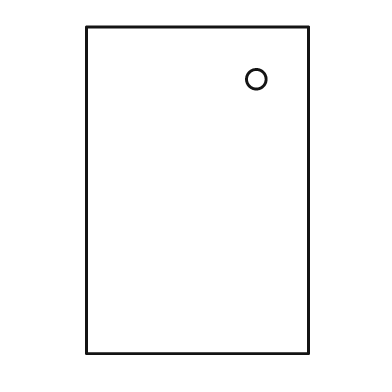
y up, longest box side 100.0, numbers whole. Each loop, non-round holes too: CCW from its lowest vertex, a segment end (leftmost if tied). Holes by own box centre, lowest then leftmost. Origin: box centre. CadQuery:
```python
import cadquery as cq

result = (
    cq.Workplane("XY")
    .moveTo(-34.0, -50.0)
    .lineTo(34.0, -50.0)
    .lineTo(34.0, 50.0)
    .lineTo(-34.0, 50.0)
    .close()
    .moveTo(18.0, 34.0)
    .circle(3.0)
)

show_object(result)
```